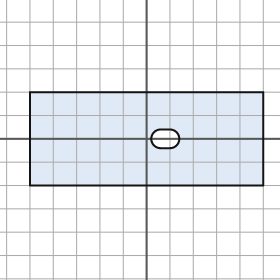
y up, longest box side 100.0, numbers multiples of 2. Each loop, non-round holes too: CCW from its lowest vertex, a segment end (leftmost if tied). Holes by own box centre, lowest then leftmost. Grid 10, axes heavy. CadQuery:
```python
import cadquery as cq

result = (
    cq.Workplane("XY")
    .moveTo(-50.0, -20.0)
    .lineTo(50.0, -20.0)
    .lineTo(50.0, 20.0)
    .lineTo(-50.0, 20.0)
    .close()
    .moveTo(6.0, -4.0)
    .lineTo(10.0, -4.0)
    .threePointArc((14.0, 0.0), (10.0, 4.0))
    .lineTo(6.0, 4.0)
    .threePointArc((2.0, 0.0), (6.0, -4.0))
    .close()
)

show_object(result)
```